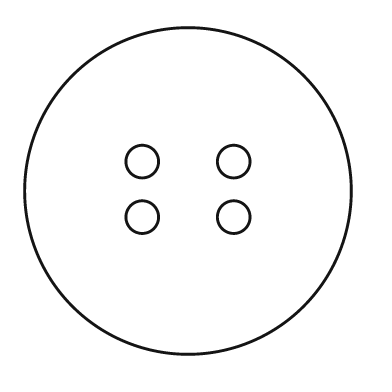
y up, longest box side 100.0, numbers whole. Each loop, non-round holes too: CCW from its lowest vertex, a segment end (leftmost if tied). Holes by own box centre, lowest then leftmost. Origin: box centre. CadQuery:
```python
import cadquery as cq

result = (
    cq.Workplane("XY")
    .moveTo(0.0, 0.0)
    .circle(50.0)
    .moveTo(-14.0, -8.0)
    .circle(5.0)
    .moveTo(14.0, -8.0)
    .circle(5.0)
    .moveTo(-14.0, 9.0)
    .circle(5.0)
    .moveTo(14.0, 9.0)
    .circle(5.0)
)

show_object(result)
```